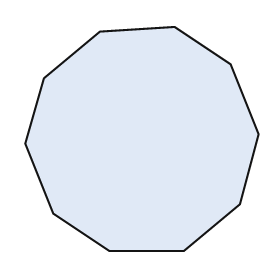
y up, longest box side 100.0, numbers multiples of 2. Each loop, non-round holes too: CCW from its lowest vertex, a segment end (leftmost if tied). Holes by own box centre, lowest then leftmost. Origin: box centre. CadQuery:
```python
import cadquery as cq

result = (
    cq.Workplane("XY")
    .moveTo(-14.0, -48.0)
    .lineTo(18.0, -48.0)
    .lineTo(42.0, -28.0)
    .lineTo(50.0, 2.0)
    .lineTo(38.0, 32.0)
    .lineTo(14.0, 48.0)
    .lineTo(-18.0, 46.0)
    .lineTo(-42.0, 26.0)
    .lineTo(-50.0, -2.0)
    .lineTo(-38.0, -32.0)
    .close()
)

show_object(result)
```